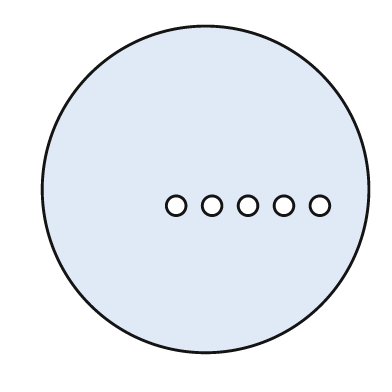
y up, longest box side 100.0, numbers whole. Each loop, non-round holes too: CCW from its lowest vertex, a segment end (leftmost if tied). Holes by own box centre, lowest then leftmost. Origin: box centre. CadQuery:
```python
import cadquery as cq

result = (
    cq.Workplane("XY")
    .moveTo(0.0, 0.0)
    .circle(50.0)
    .moveTo(-9.0, -5.0)
    .circle(3.0)
    .moveTo(2.0, -5.0)
    .circle(3.0)
    .moveTo(13.0, -5.0)
    .circle(3.0)
    .moveTo(24.0, -5.0)
    .circle(3.0)
    .moveTo(35.0, -5.0)
    .circle(3.0)
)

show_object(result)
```